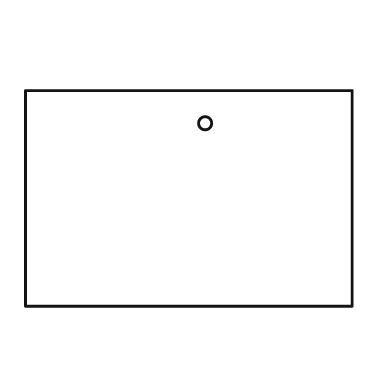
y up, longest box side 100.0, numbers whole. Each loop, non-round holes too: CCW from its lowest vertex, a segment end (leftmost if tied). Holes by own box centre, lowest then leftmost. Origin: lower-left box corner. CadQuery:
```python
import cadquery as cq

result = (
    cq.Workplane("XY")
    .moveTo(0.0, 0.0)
    .lineTo(100.0, 0.0)
    .lineTo(100.0, 66.0)
    .lineTo(0.0, 66.0)
    .close()
    .moveTo(55.0, 56.0)
    .circle(2.0)
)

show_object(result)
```